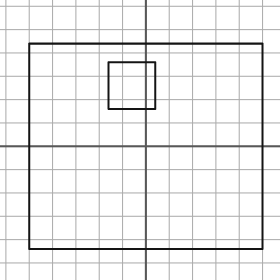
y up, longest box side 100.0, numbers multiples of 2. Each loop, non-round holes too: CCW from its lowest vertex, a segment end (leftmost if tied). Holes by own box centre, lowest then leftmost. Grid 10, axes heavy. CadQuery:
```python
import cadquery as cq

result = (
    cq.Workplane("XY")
    .moveTo(-50.0, -44.0)
    .lineTo(50.0, -44.0)
    .lineTo(50.0, 44.0)
    .lineTo(-50.0, 44.0)
    .close()
    .moveTo(-16.0, 16.0)
    .lineTo(4.0, 16.0)
    .lineTo(4.0, 36.0)
    .lineTo(-16.0, 36.0)
    .close()
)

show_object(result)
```